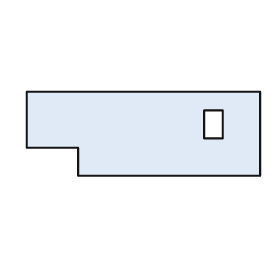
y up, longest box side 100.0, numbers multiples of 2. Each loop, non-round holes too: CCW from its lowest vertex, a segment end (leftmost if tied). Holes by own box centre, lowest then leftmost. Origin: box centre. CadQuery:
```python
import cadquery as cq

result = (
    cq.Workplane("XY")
    .moveTo(-28.0, -18.0)
    .lineTo(50.0, -18.0)
    .lineTo(50.0, 18.0)
    .lineTo(-50.0, 18.0)
    .lineTo(-50.0, -6.0)
    .lineTo(-28.0, -6.0)
    .close()
    .moveTo(26.0, -2.0)
    .lineTo(34.0, -2.0)
    .lineTo(34.0, 10.0)
    .lineTo(26.0, 10.0)
    .close()
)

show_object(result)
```